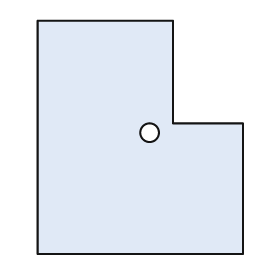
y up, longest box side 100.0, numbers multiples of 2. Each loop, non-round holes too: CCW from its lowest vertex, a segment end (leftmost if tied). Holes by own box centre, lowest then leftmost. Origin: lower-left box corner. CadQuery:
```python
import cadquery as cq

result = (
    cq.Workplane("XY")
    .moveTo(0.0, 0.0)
    .lineTo(88.0, 0.0)
    .lineTo(88.0, 56.0)
    .lineTo(58.0, 56.0)
    .lineTo(58.0, 100.0)
    .lineTo(0.0, 100.0)
    .close()
    .moveTo(48.0, 52.0)
    .circle(4.0)
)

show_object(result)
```